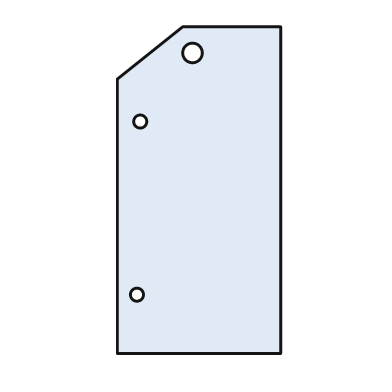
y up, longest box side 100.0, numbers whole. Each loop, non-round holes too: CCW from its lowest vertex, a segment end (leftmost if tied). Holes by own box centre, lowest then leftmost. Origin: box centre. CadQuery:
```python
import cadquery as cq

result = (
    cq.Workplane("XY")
    .moveTo(-25.0, -50.0)
    .lineTo(25.0, -50.0)
    .lineTo(25.0, 50.0)
    .lineTo(-5.0, 50.0)
    .lineTo(-25.0, 34.0)
    .close()
    .moveTo(-19.0, -32.0)
    .circle(2.0)
    .moveTo(-18.0, 21.0)
    .circle(2.0)
    .moveTo(-2.0, 42.0)
    .circle(3.0)
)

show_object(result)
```